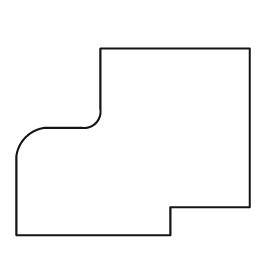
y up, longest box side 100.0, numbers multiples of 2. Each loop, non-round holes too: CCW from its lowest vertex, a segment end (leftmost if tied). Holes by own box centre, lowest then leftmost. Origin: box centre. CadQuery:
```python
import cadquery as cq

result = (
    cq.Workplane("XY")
    .moveTo(-50.0, -40.0)
    .lineTo(16.0, -40.0)
    .lineTo(16.0, -28.0)
    .lineTo(50.0, -28.0)
    .lineTo(50.0, 40.0)
    .lineTo(-14.0, 40.0)
    .lineTo(-14.0, 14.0)
    .threePointArc((-16.0, 8.0), (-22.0, 6.0))
    .lineTo(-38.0, 6.0)
    .threePointArc((-46.0, 2.0), (-50.0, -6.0))
    .close()
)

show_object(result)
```